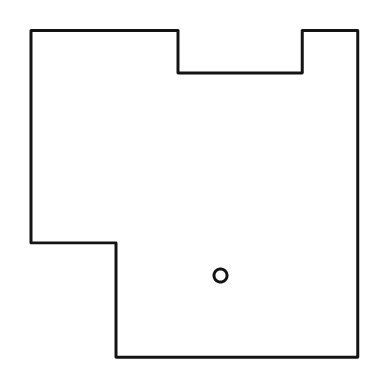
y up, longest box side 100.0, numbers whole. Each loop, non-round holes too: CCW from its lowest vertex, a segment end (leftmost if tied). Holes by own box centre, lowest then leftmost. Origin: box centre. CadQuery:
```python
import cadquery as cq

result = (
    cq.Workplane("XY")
    .moveTo(-24.0, -50.0)
    .lineTo(50.0, -50.0)
    .lineTo(50.0, 50.0)
    .lineTo(33.0, 50.0)
    .lineTo(33.0, 37.0)
    .lineTo(-5.0, 37.0)
    .lineTo(-5.0, 50.0)
    .lineTo(-50.0, 50.0)
    .lineTo(-50.0, -15.0)
    .lineTo(-24.0, -15.0)
    .close()
    .moveTo(8.0, -25.0)
    .circle(2.0)
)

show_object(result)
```